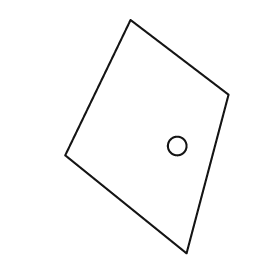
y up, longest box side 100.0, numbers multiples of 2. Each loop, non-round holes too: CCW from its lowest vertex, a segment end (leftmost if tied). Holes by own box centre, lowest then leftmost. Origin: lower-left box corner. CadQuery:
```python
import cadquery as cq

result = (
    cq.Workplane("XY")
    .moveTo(52.0, 0.0)
    .lineTo(70.0, 68.0)
    .lineTo(28.0, 100.0)
    .lineTo(0.0, 42.0)
    .close()
    .moveTo(48.0, 46.0)
    .circle(4.0)
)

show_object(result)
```